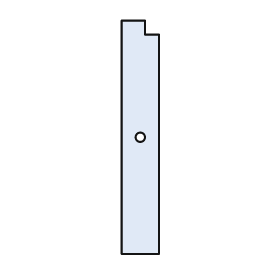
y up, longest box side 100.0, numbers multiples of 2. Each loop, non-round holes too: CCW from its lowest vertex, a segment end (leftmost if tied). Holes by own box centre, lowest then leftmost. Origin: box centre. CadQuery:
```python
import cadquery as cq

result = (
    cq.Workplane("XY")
    .moveTo(-8.0, -50.0)
    .lineTo(8.0, -50.0)
    .lineTo(8.0, 44.0)
    .lineTo(2.0, 44.0)
    .lineTo(2.0, 50.0)
    .lineTo(-8.0, 50.0)
    .close()
    .moveTo(0.0, 0.0)
    .circle(2.0)
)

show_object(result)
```